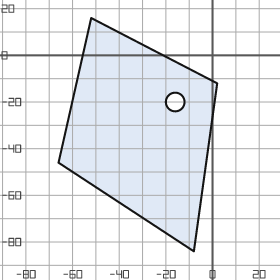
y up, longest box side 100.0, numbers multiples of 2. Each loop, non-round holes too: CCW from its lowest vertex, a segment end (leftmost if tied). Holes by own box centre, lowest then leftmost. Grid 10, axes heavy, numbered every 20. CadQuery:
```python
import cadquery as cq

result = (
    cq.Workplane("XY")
    .moveTo(-8.0, -84.0)
    .lineTo(2.0, -12.0)
    .lineTo(-52.0, 16.0)
    .lineTo(-66.0, -46.0)
    .close()
    .moveTo(-16.0, -20.0)
    .circle(4.0)
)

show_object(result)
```